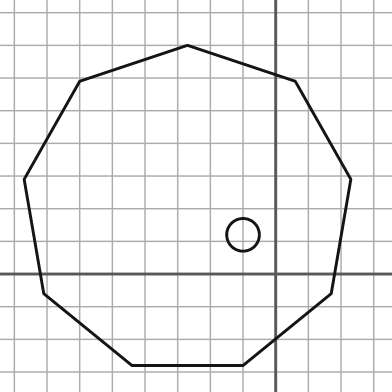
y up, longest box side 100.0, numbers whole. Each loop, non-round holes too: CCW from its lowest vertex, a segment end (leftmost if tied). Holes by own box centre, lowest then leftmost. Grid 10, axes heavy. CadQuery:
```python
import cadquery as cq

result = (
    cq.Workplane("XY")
    .moveTo(-44.0, -28.0)
    .lineTo(-10.0, -28.0)
    .lineTo(17.0, -6.0)
    .lineTo(23.0, 29.0)
    .lineTo(6.0, 59.0)
    .lineTo(-27.0, 70.0)
    .lineTo(-60.0, 59.0)
    .lineTo(-77.0, 29.0)
    .lineTo(-71.0, -6.0)
    .close()
    .moveTo(-10.0, 12.0)
    .circle(5.0)
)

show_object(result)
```